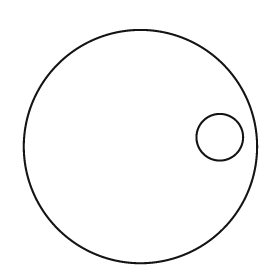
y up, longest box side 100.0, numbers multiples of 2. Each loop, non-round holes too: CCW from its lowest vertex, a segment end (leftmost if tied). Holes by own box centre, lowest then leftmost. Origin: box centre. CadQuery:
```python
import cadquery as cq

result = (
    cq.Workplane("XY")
    .moveTo(0.0, 0.0)
    .circle(50.0)
    .moveTo(34.0, 4.0)
    .circle(10.0)
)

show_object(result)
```